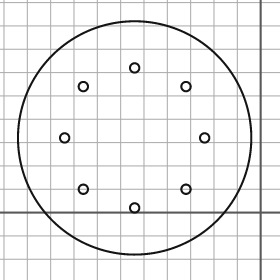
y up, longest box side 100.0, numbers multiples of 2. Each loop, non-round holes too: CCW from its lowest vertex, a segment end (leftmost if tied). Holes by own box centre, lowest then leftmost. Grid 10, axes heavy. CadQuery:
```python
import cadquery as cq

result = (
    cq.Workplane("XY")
    .moveTo(-54.0, 32.0)
    .circle(50.0)
    .moveTo(-54.0, 2.0)
    .circle(2.0)
    .moveTo(-76.0, 10.0)
    .circle(2.0)
    .moveTo(-32.0, 10.0)
    .circle(2.0)
    .moveTo(-84.0, 32.0)
    .circle(2.0)
    .moveTo(-24.0, 32.0)
    .circle(2.0)
    .moveTo(-76.0, 54.0)
    .circle(2.0)
    .moveTo(-32.0, 54.0)
    .circle(2.0)
    .moveTo(-54.0, 62.0)
    .circle(2.0)
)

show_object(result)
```